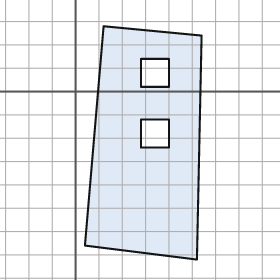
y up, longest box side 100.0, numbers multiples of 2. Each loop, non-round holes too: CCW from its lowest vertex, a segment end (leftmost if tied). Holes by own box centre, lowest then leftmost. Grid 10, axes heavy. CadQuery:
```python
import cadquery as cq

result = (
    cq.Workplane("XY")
    .moveTo(52.0, -72.0)
    .lineTo(54.0, 24.0)
    .lineTo(12.0, 28.0)
    .lineTo(4.0, -66.0)
    .close()
    .moveTo(28.0, -24.0)
    .lineTo(40.0, -24.0)
    .lineTo(40.0, -12.0)
    .lineTo(28.0, -12.0)
    .close()
    .moveTo(28.0, 2.0)
    .lineTo(40.0, 2.0)
    .lineTo(40.0, 14.0)
    .lineTo(28.0, 14.0)
    .close()
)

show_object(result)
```